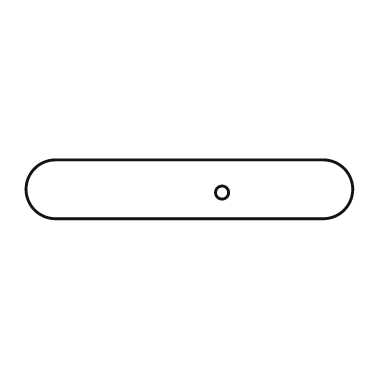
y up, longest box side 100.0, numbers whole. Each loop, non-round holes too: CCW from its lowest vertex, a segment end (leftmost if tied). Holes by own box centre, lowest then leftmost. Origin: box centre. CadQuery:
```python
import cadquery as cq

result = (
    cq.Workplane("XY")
    .moveTo(-41.0, -9.0)
    .lineTo(41.0, -9.0)
    .threePointArc((50.0, 0.0), (41.0, 9.0))
    .lineTo(-41.0, 9.0)
    .threePointArc((-50.0, 0.0), (-41.0, -9.0))
    .close()
    .moveTo(10.0, -1.0)
    .circle(2.0)
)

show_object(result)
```